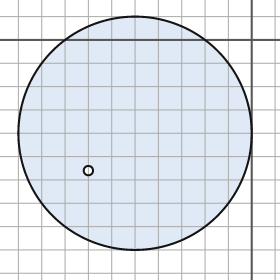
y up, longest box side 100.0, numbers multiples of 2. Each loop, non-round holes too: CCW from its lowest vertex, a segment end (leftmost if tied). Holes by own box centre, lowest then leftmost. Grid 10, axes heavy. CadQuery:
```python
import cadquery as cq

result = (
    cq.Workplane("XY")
    .moveTo(-50.0, -40.0)
    .circle(50.0)
    .moveTo(-70.0, -56.0)
    .circle(2.0)
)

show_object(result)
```